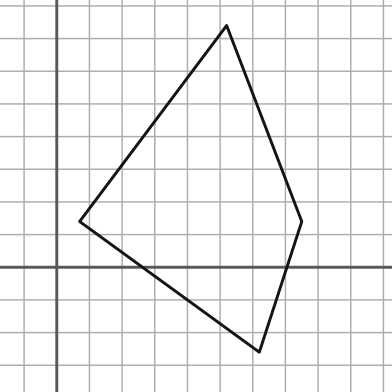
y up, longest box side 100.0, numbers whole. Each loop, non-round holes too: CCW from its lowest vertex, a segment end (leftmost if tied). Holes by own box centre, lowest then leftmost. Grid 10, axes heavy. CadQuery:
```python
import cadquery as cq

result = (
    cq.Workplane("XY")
    .moveTo(62.0, -26.0)
    .lineTo(75.0, 14.0)
    .lineTo(52.0, 74.0)
    .lineTo(7.0, 14.0)
    .close()
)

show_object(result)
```